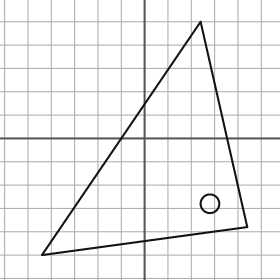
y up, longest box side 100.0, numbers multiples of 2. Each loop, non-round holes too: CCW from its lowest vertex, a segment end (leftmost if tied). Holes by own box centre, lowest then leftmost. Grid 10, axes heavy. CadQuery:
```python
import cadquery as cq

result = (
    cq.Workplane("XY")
    .moveTo(-44.0, -50.0)
    .lineTo(44.0, -38.0)
    .lineTo(24.0, 50.0)
    .close()
    .moveTo(28.0, -28.0)
    .circle(4.0)
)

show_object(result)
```